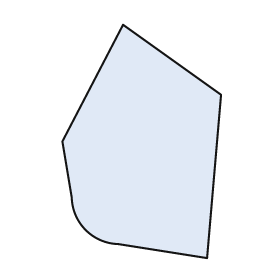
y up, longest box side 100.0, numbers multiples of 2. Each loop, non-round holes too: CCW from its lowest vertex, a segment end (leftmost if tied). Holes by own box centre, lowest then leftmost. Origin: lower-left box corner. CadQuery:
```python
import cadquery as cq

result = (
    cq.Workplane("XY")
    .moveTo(62.0, 0.0)
    .lineTo(68.0, 70.0)
    .lineTo(26.0, 100.0)
    .lineTo(0.0, 50.0)
    .lineTo(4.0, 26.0)
    .threePointArc((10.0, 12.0), (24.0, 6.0))
    .close()
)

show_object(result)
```